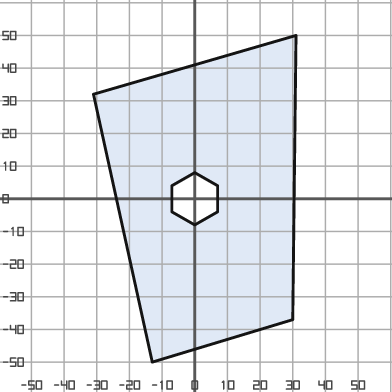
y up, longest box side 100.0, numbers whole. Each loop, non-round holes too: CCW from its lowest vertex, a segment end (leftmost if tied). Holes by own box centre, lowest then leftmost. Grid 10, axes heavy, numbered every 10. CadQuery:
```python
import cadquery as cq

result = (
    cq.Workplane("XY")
    .moveTo(-13.0, -50.0)
    .lineTo(30.0, -37.0)
    .lineTo(31.0, 50.0)
    .lineTo(-31.0, 32.0)
    .close()
    .moveTo(0.0, -8.0)
    .lineTo(7.0, -4.0)
    .lineTo(7.0, 4.0)
    .lineTo(0.0, 8.0)
    .lineTo(-7.0, 4.0)
    .lineTo(-7.0, -4.0)
    .close()
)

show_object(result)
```